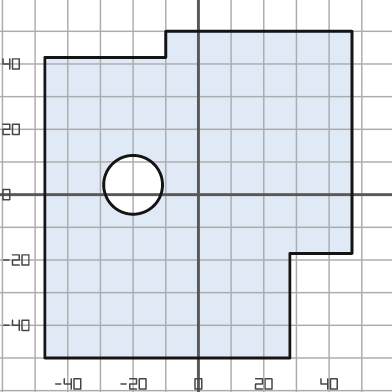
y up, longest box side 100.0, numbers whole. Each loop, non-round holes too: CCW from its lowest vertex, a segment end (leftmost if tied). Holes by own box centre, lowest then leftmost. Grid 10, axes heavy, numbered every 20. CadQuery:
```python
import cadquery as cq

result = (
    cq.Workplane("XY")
    .moveTo(-47.0, -50.0)
    .lineTo(28.0, -50.0)
    .lineTo(28.0, -18.0)
    .lineTo(47.0, -18.0)
    .lineTo(47.0, 50.0)
    .lineTo(-10.0, 50.0)
    .lineTo(-10.0, 42.0)
    .lineTo(-47.0, 42.0)
    .close()
    .moveTo(-20.0, 3.0)
    .circle(9.0)
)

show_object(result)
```